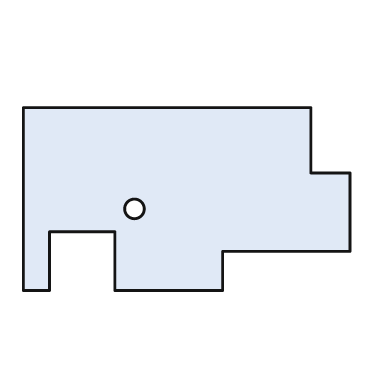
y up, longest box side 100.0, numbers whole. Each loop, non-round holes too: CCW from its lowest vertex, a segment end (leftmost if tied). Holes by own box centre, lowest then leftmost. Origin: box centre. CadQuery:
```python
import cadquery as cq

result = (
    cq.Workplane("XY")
    .moveTo(-50.0, -28.0)
    .lineTo(-42.0, -28.0)
    .lineTo(-42.0, -10.0)
    .lineTo(-22.0, -10.0)
    .lineTo(-22.0, -28.0)
    .lineTo(11.0, -28.0)
    .lineTo(11.0, -16.0)
    .lineTo(50.0, -16.0)
    .lineTo(50.0, 8.0)
    .lineTo(38.0, 8.0)
    .lineTo(38.0, 28.0)
    .lineTo(-50.0, 28.0)
    .close()
    .moveTo(-16.0, -3.0)
    .circle(3.0)
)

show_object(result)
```